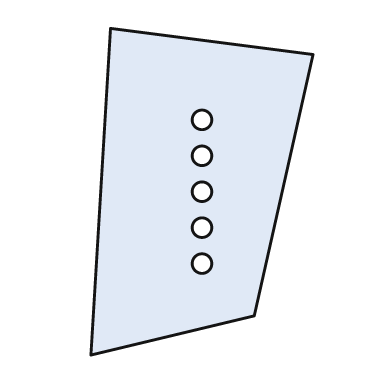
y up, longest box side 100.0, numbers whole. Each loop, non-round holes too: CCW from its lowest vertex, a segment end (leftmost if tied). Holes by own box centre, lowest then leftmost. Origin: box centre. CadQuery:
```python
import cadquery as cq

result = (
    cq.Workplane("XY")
    .moveTo(-34.0, -50.0)
    .lineTo(16.0, -38.0)
    .lineTo(34.0, 42.0)
    .lineTo(-28.0, 50.0)
    .close()
    .moveTo(0.0, -22.0)
    .circle(3.0)
    .moveTo(0.0, -11.0)
    .circle(3.0)
    .moveTo(0.0, 0.0)
    .circle(3.0)
    .moveTo(0.0, 11.0)
    .circle(3.0)
    .moveTo(0.0, 22.0)
    .circle(3.0)
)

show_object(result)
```